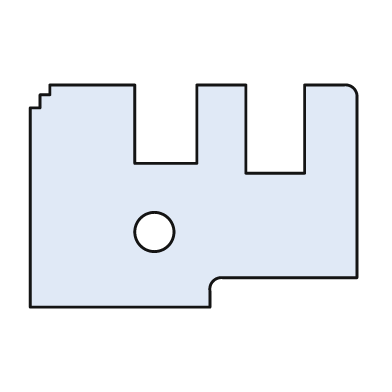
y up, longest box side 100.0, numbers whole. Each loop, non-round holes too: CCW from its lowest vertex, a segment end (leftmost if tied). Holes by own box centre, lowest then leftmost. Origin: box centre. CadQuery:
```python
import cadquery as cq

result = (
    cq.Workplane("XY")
    .moveTo(-50.0, -34.0)
    .lineTo(5.0, -34.0)
    .lineTo(5.0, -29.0)
    .threePointArc((6.0, -26.0), (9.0, -25.0))
    .lineTo(50.0, -25.0)
    .lineTo(50.0, 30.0)
    .threePointArc((49.0, 33.0), (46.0, 34.0))
    .lineTo(34.0, 34.0)
    .lineTo(34.0, 7.0)
    .lineTo(16.0, 7.0)
    .lineTo(16.0, 34.0)
    .lineTo(1.0, 34.0)
    .lineTo(1.0, 10.0)
    .lineTo(-18.0, 10.0)
    .lineTo(-18.0, 34.0)
    .lineTo(-44.0, 34.0)
    .lineTo(-44.0, 31.0)
    .lineTo(-47.0, 31.0)
    .lineTo(-47.0, 27.0)
    .lineTo(-50.0, 27.0)
    .close()
    .moveTo(-12.0, -11.0)
    .circle(6.0)
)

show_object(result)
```